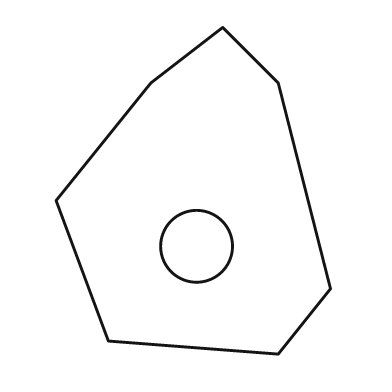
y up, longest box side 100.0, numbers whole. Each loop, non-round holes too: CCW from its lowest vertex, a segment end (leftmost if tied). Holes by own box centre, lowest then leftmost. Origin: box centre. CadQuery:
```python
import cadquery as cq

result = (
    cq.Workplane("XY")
    .moveTo(26.0, -50.0)
    .lineTo(42.0, -30.0)
    .lineTo(26.0, 33.0)
    .lineTo(9.0, 50.0)
    .lineTo(-13.0, 33.0)
    .lineTo(-42.0, -3.0)
    .lineTo(-26.0, -46.0)
    .close()
    .moveTo(1.0, -17.0)
    .circle(11.0)
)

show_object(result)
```